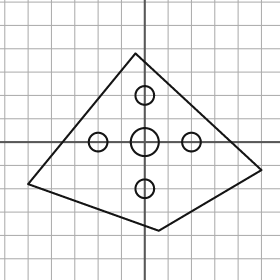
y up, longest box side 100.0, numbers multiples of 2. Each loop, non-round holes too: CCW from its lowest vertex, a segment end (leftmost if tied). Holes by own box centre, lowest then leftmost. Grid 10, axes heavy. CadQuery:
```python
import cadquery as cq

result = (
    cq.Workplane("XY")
    .moveTo(6.0, -38.0)
    .lineTo(50.0, -12.0)
    .lineTo(-4.0, 38.0)
    .lineTo(-50.0, -18.0)
    .close()
    .moveTo(0.0, -20.0)
    .circle(4.0)
    .moveTo(-20.0, 0.0)
    .circle(4.0)
    .moveTo(0.0, 0.0)
    .circle(6.0)
    .moveTo(20.0, 0.0)
    .circle(4.0)
    .moveTo(0.0, 20.0)
    .circle(4.0)
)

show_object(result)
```